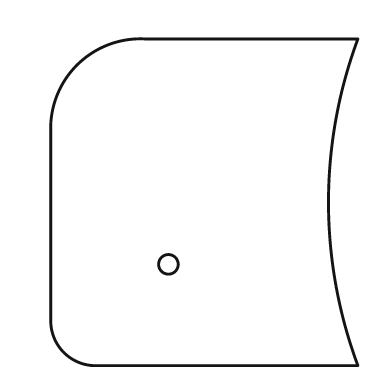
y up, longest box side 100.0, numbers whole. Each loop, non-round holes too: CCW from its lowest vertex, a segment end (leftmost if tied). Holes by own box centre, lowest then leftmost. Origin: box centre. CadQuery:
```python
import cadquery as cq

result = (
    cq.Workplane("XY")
    .moveTo(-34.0, -50.0)
    .lineTo(47.0, -50.0)
    .threePointArc((38.0, 0.0), (47.0, 50.0))
    .lineTo(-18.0, 50.0)
    .threePointArc((-39.0, 42.0), (-47.0, 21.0))
    .lineTo(-47.0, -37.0)
    .threePointArc((-43.0, -46.0), (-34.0, -50.0))
    .close()
    .moveTo(-11.0, -19.0)
    .circle(3.0)
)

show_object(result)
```